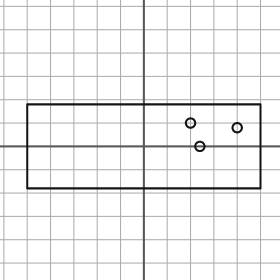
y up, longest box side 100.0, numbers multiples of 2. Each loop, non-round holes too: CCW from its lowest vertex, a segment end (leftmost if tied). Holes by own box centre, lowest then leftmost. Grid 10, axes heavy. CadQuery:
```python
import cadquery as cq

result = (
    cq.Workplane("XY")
    .moveTo(-50.0, -18.0)
    .lineTo(50.0, -18.0)
    .lineTo(50.0, 18.0)
    .lineTo(-50.0, 18.0)
    .close()
    .moveTo(24.0, 0.0)
    .circle(2.0)
    .moveTo(40.0, 8.0)
    .circle(2.0)
    .moveTo(20.0, 10.0)
    .circle(2.0)
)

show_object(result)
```